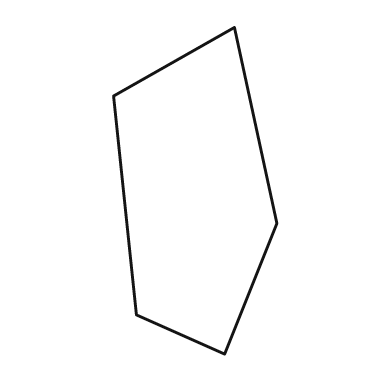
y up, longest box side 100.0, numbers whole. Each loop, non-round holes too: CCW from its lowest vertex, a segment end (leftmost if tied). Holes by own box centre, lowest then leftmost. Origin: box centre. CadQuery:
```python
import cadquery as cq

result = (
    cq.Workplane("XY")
    .moveTo(9.0, -50.0)
    .lineTo(25.0, -10.0)
    .lineTo(12.0, 50.0)
    .lineTo(-25.0, 29.0)
    .lineTo(-18.0, -38.0)
    .close()
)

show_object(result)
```